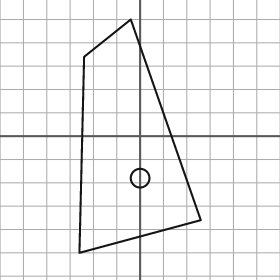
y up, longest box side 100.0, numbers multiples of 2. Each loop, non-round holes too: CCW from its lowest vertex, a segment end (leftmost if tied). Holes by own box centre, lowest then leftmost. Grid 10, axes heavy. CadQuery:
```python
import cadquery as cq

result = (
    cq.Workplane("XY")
    .moveTo(-26.0, -50.0)
    .lineTo(26.0, -36.0)
    .lineTo(-4.0, 50.0)
    .lineTo(-24.0, 34.0)
    .close()
    .moveTo(0.0, -18.0)
    .circle(4.0)
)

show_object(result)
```